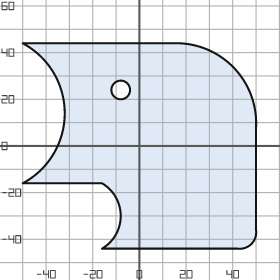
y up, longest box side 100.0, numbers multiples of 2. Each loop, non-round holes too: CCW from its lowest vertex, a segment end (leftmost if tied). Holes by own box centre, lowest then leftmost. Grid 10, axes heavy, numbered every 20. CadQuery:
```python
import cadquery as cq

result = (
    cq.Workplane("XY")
    .moveTo(-16.0, -44.0)
    .lineTo(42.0, -44.0)
    .threePointArc((48.0, -42.0), (50.0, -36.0))
    .lineTo(50.0, 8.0)
    .threePointArc((40.0, 34.0), (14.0, 44.0))
    .lineTo(-50.0, 44.0)
    .threePointArc((-32.0, 14.0), (-50.0, -16.0))
    .lineTo(-16.0, -16.0)
    .threePointArc((-8.0, -30.0), (-16.0, -44.0))
    .close()
    .moveTo(-8.0, 24.0)
    .circle(4.0)
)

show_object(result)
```